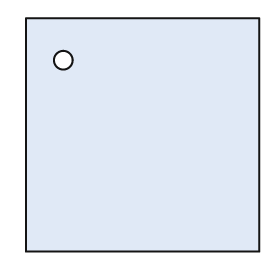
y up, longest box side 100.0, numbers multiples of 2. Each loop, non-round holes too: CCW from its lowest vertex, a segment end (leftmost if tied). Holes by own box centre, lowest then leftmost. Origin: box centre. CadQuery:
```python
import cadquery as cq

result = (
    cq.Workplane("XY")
    .moveTo(-50.0, -50.0)
    .lineTo(50.0, -50.0)
    .lineTo(50.0, 50.0)
    .lineTo(-50.0, 50.0)
    .close()
    .moveTo(-34.0, 32.0)
    .circle(4.0)
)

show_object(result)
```